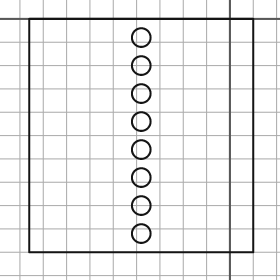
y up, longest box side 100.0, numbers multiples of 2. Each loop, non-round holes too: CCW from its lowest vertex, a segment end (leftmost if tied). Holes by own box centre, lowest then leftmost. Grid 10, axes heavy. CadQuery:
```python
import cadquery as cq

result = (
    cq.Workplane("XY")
    .moveTo(-86.0, -100.0)
    .lineTo(10.0, -100.0)
    .lineTo(10.0, 0.0)
    .lineTo(-86.0, 0.0)
    .close()
    .moveTo(-38.0, -92.0)
    .circle(4.0)
    .moveTo(-38.0, -80.0)
    .circle(4.0)
    .moveTo(-38.0, -68.0)
    .circle(4.0)
    .moveTo(-38.0, -56.0)
    .circle(4.0)
    .moveTo(-38.0, -44.0)
    .circle(4.0)
    .moveTo(-38.0, -32.0)
    .circle(4.0)
    .moveTo(-38.0, -20.0)
    .circle(4.0)
    .moveTo(-38.0, -8.0)
    .circle(4.0)
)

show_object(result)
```